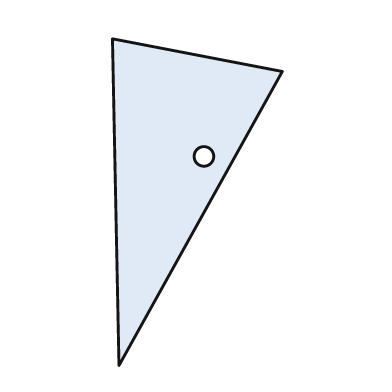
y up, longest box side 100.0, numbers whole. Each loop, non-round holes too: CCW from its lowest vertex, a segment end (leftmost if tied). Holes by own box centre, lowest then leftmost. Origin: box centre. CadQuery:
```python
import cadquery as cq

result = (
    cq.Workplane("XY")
    .moveTo(-24.0, -50.0)
    .lineTo(26.0, 40.0)
    .lineTo(-26.0, 50.0)
    .close()
    .moveTo(2.0, 14.0)
    .circle(3.0)
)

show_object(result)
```